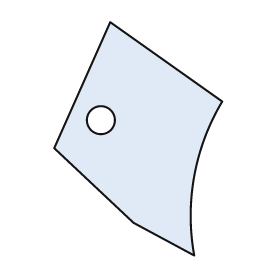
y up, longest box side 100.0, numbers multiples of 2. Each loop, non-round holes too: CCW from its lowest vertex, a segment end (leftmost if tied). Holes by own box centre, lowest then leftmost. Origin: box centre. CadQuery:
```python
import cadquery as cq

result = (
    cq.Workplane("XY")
    .moveTo(24.0, -50.0)
    .threePointArc((24.0, -16.0), (36.0, 16.0))
    .lineTo(-12.0, 50.0)
    .lineTo(-36.0, -4.0)
    .lineTo(-2.0, -36.0)
    .close()
    .moveTo(-16.0, 8.0)
    .circle(6.0)
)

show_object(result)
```